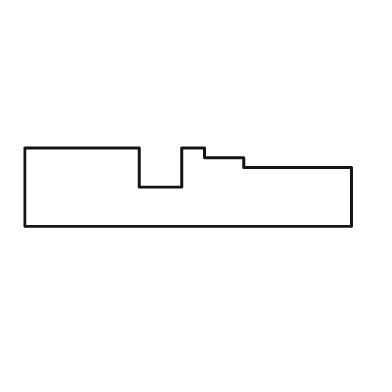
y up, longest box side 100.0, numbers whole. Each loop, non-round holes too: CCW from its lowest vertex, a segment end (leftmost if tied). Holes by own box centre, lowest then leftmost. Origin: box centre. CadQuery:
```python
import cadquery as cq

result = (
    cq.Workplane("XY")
    .moveTo(-50.0, -12.0)
    .lineTo(50.0, -12.0)
    .lineTo(50.0, 6.0)
    .lineTo(17.0, 6.0)
    .lineTo(17.0, 9.0)
    .lineTo(5.0, 9.0)
    .lineTo(5.0, 12.0)
    .lineTo(-2.0, 12.0)
    .lineTo(-2.0, 0.0)
    .lineTo(-15.0, 0.0)
    .lineTo(-15.0, 12.0)
    .lineTo(-50.0, 12.0)
    .close()
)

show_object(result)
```